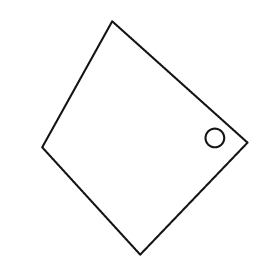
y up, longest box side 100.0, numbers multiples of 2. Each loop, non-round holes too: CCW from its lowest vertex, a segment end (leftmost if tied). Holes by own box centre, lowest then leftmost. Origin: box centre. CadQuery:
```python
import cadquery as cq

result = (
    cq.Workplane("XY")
    .moveTo(-2.0, -50.0)
    .lineTo(44.0, -2.0)
    .lineTo(-14.0, 50.0)
    .lineTo(-44.0, -4.0)
    .close()
    .moveTo(30.0, 0.0)
    .circle(4.0)
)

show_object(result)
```